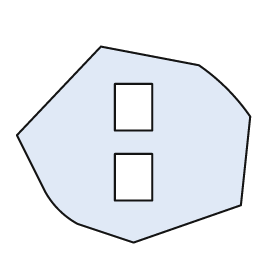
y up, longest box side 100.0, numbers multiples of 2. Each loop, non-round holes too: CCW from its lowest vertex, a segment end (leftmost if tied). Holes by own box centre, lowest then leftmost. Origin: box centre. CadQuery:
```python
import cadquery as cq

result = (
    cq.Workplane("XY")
    .moveTo(0.0, -42.0)
    .lineTo(46.0, -26.0)
    .lineTo(50.0, 12.0)
    .threePointArc((40.0, 24.0), (28.0, 34.0))
    .lineTo(-14.0, 42.0)
    .lineTo(-50.0, 4.0)
    .lineTo(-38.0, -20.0)
    .threePointArc((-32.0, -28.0), (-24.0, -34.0))
    .close()
    .moveTo(-8.0, -24.0)
    .lineTo(8.0, -24.0)
    .lineTo(8.0, -4.0)
    .lineTo(-8.0, -4.0)
    .close()
    .moveTo(-8.0, 6.0)
    .lineTo(8.0, 6.0)
    .lineTo(8.0, 26.0)
    .lineTo(-8.0, 26.0)
    .close()
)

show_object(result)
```